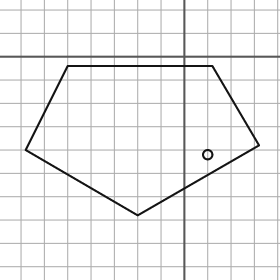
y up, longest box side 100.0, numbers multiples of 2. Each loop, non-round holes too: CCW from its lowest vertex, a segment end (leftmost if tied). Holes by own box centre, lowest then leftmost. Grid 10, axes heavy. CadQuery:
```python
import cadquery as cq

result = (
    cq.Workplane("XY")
    .moveTo(-20.0, -68.0)
    .lineTo(32.0, -38.0)
    .lineTo(12.0, -4.0)
    .lineTo(-50.0, -4.0)
    .lineTo(-68.0, -40.0)
    .close()
    .moveTo(10.0, -42.0)
    .circle(2.0)
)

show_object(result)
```